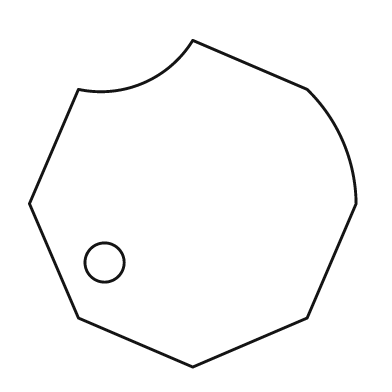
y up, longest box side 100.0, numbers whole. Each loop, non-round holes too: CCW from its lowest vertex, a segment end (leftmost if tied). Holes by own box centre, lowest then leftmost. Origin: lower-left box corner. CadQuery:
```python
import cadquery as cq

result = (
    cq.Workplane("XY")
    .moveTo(50.0, 0.0)
    .lineTo(85.0, 15.0)
    .lineTo(100.0, 50.0)
    .threePointArc((96.0, 69.0), (85.0, 85.0))
    .lineTo(50.0, 100.0)
    .threePointArc((35.0, 87.0), (15.0, 85.0))
    .lineTo(0.0, 50.0)
    .lineTo(15.0, 15.0)
    .close()
    .moveTo(23.0, 32.0)
    .circle(6.0)
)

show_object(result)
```